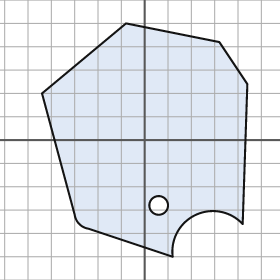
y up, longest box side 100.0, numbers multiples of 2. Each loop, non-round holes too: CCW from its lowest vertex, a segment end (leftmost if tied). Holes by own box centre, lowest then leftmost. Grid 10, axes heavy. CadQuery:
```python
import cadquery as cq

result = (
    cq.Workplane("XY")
    .moveTo(12.0, -50.0)
    .threePointArc((22.0, -32.0), (42.0, -36.0))
    .lineTo(44.0, 24.0)
    .lineTo(32.0, 42.0)
    .lineTo(-8.0, 50.0)
    .lineTo(-44.0, 20.0)
    .lineTo(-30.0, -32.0)
    .threePointArc((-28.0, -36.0), (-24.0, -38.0))
    .close()
    .moveTo(6.0, -28.0)
    .circle(4.0)
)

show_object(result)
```